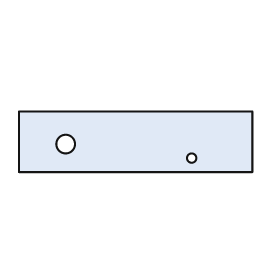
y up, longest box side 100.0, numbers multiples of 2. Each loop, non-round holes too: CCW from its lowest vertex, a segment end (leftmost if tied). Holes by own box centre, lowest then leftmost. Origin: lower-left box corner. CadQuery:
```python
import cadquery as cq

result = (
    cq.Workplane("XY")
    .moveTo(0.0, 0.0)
    .lineTo(100.0, 0.0)
    .lineTo(100.0, 26.0)
    .lineTo(0.0, 26.0)
    .close()
    .moveTo(74.0, 6.0)
    .circle(2.0)
    .moveTo(20.0, 12.0)
    .circle(4.0)
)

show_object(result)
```